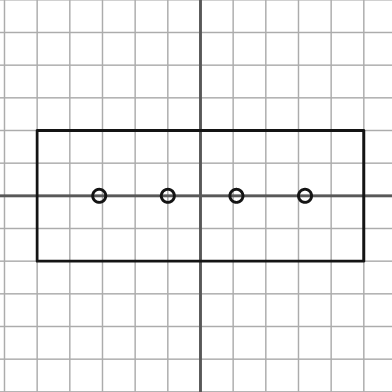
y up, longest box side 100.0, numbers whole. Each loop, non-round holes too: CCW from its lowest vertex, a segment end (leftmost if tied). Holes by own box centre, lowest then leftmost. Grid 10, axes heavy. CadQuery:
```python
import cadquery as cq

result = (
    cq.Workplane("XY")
    .moveTo(-50.0, -20.0)
    .lineTo(50.0, -20.0)
    .lineTo(50.0, 20.0)
    .lineTo(-50.0, 20.0)
    .close()
    .moveTo(-31.0, 0.0)
    .circle(2.0)
    .moveTo(-10.0, 0.0)
    .circle(2.0)
    .moveTo(11.0, 0.0)
    .circle(2.0)
    .moveTo(32.0, 0.0)
    .circle(2.0)
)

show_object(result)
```